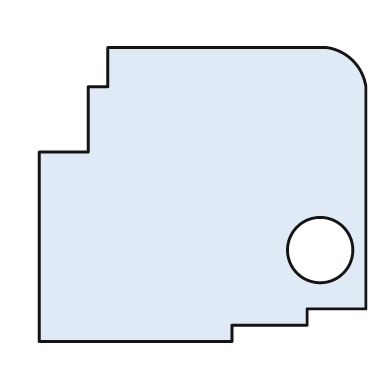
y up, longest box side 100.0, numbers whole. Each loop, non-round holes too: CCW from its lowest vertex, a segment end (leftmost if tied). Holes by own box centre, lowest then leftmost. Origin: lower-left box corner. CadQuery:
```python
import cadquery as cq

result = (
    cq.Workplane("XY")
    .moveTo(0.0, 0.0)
    .lineTo(59.0, 0.0)
    .lineTo(59.0, 5.0)
    .lineTo(82.0, 5.0)
    .lineTo(82.0, 10.0)
    .lineTo(100.0, 10.0)
    .lineTo(100.0, 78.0)
    .threePointArc((96.0, 86.0), (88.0, 90.0))
    .lineTo(21.0, 90.0)
    .lineTo(21.0, 78.0)
    .lineTo(15.0, 78.0)
    .lineTo(15.0, 58.0)
    .lineTo(0.0, 58.0)
    .close()
    .moveTo(86.0, 28.0)
    .circle(10.0)
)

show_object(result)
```